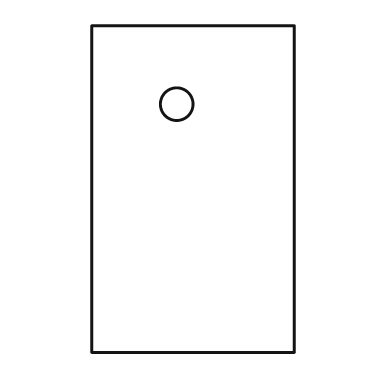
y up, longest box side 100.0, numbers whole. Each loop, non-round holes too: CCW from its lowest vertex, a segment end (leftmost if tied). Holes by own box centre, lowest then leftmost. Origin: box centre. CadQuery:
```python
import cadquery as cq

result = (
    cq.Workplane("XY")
    .moveTo(-31.0, -50.0)
    .lineTo(31.0, -50.0)
    .lineTo(31.0, 50.0)
    .lineTo(-31.0, 50.0)
    .close()
    .moveTo(-5.0, 26.0)
    .circle(5.0)
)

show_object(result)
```